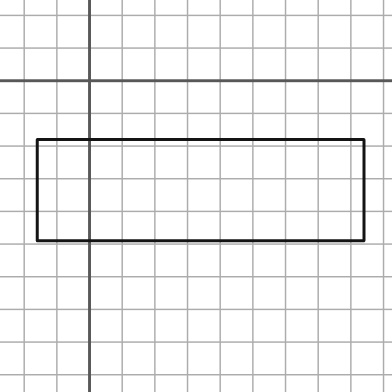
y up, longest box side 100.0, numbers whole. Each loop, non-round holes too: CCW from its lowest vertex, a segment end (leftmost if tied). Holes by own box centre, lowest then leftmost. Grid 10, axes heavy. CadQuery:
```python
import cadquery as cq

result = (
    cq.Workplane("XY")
    .moveTo(-16.0, -49.0)
    .lineTo(84.0, -49.0)
    .lineTo(84.0, -18.0)
    .lineTo(-16.0, -18.0)
    .close()
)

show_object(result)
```